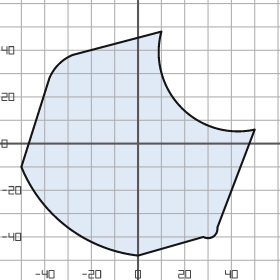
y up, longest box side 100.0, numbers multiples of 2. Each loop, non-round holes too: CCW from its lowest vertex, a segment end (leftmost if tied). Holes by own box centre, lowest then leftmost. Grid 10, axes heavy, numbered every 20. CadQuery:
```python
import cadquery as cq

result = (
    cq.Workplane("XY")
    .moveTo(0.0, -48.0)
    .lineTo(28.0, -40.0)
    .threePointArc((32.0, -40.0), (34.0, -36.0))
    .lineTo(50.0, 6.0)
    .threePointArc((18.0, 16.0), (10.0, 48.0))
    .lineTo(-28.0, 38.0)
    .threePointArc((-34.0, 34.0), (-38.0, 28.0))
    .lineTo(-50.0, -10.0)
    .threePointArc((-30.0, -36.0), (0.0, -48.0))
    .close()
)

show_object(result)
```